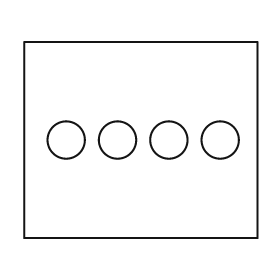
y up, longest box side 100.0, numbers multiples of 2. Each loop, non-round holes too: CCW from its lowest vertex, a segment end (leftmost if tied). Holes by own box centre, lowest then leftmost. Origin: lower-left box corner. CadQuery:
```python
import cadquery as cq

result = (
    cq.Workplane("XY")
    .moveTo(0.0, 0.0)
    .lineTo(100.0, 0.0)
    .lineTo(100.0, 84.0)
    .lineTo(0.0, 84.0)
    .close()
    .moveTo(18.0, 42.0)
    .circle(8.0)
    .moveTo(40.0, 42.0)
    .circle(8.0)
    .moveTo(62.0, 42.0)
    .circle(8.0)
    .moveTo(84.0, 42.0)
    .circle(8.0)
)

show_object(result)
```